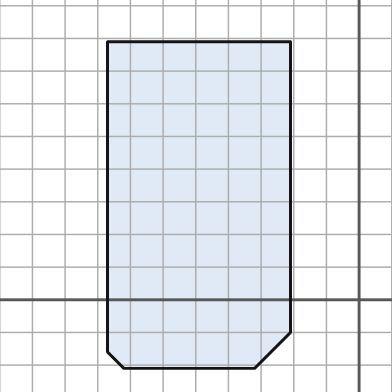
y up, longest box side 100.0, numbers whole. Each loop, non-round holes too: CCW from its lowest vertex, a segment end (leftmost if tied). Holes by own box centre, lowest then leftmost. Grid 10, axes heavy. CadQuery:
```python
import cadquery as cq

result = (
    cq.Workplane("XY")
    .moveTo(-72.0, -21.0)
    .lineTo(-32.0, -21.0)
    .lineTo(-21.0, -10.0)
    .lineTo(-21.0, 79.0)
    .lineTo(-77.0, 79.0)
    .lineTo(-77.0, -16.0)
    .close()
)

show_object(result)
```